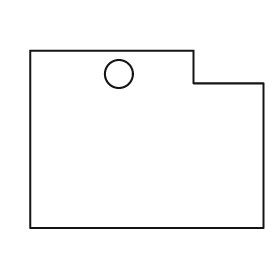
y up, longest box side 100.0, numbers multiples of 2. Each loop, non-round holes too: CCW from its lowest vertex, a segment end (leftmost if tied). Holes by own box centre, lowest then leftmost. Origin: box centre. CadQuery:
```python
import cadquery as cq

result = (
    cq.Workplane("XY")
    .moveTo(-50.0, -38.0)
    .lineTo(50.0, -38.0)
    .lineTo(50.0, 24.0)
    .lineTo(20.0, 24.0)
    .lineTo(20.0, 38.0)
    .lineTo(-50.0, 38.0)
    .close()
    .moveTo(-12.0, 28.0)
    .circle(6.0)
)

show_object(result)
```